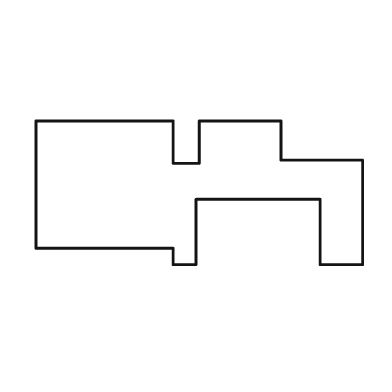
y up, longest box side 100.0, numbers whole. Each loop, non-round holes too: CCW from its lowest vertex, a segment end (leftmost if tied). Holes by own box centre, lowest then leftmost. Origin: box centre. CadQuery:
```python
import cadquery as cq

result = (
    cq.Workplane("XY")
    .moveTo(-8.0, -22.0)
    .lineTo(-1.0, -22.0)
    .lineTo(-1.0, -2.0)
    .lineTo(37.0, -2.0)
    .lineTo(37.0, -22.0)
    .lineTo(50.0, -22.0)
    .lineTo(50.0, 10.0)
    .lineTo(25.0, 10.0)
    .lineTo(25.0, 22.0)
    .lineTo(0.0, 22.0)
    .lineTo(0.0, 9.0)
    .lineTo(-8.0, 9.0)
    .lineTo(-8.0, 22.0)
    .lineTo(-50.0, 22.0)
    .lineTo(-50.0, -17.0)
    .lineTo(-8.0, -17.0)
    .close()
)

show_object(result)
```